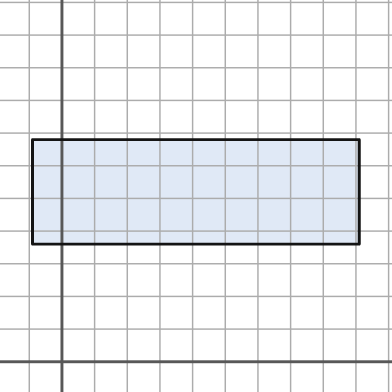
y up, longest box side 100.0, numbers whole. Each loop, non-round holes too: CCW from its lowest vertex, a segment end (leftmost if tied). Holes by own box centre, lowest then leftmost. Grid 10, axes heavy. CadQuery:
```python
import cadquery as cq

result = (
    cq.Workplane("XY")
    .moveTo(-9.0, 36.0)
    .lineTo(91.0, 36.0)
    .lineTo(91.0, 68.0)
    .lineTo(-9.0, 68.0)
    .close()
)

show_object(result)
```